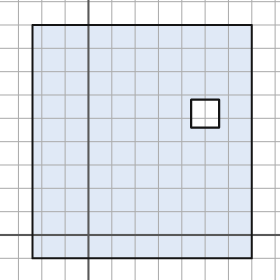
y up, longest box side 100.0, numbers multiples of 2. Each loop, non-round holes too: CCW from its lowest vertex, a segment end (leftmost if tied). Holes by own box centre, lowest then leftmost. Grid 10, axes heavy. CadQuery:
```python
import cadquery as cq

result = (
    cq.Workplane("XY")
    .moveTo(-24.0, -10.0)
    .lineTo(70.0, -10.0)
    .lineTo(70.0, 90.0)
    .lineTo(-24.0, 90.0)
    .close()
    .moveTo(44.0, 46.0)
    .lineTo(56.0, 46.0)
    .lineTo(56.0, 58.0)
    .lineTo(44.0, 58.0)
    .close()
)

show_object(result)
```